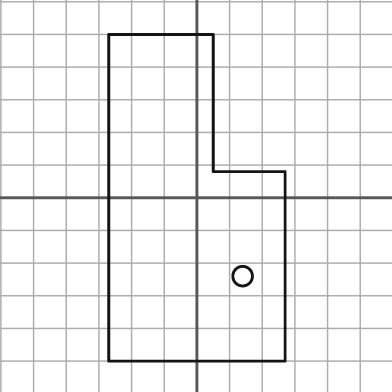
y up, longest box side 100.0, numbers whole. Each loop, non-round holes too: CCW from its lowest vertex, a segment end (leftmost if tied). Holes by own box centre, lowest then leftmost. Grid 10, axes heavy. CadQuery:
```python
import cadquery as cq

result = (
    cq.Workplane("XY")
    .moveTo(-27.0, -50.0)
    .lineTo(27.0, -50.0)
    .lineTo(27.0, 8.0)
    .lineTo(5.0, 8.0)
    .lineTo(5.0, 50.0)
    .lineTo(-27.0, 50.0)
    .close()
    .moveTo(14.0, -24.0)
    .circle(3.0)
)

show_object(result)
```